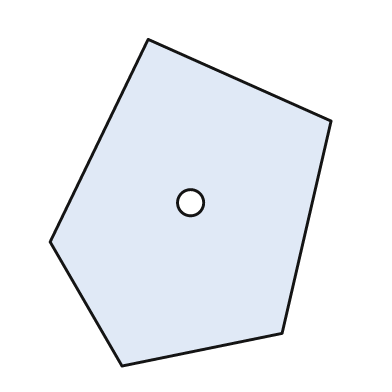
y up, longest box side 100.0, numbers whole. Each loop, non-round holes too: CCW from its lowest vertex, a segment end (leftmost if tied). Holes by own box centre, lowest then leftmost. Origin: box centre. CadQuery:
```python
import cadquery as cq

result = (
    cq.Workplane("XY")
    .moveTo(-21.0, -50.0)
    .lineTo(28.0, -40.0)
    .lineTo(43.0, 25.0)
    .lineTo(-13.0, 50.0)
    .lineTo(-43.0, -12.0)
    .close()
    .moveTo(0.0, 0.0)
    .circle(4.0)
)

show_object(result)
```